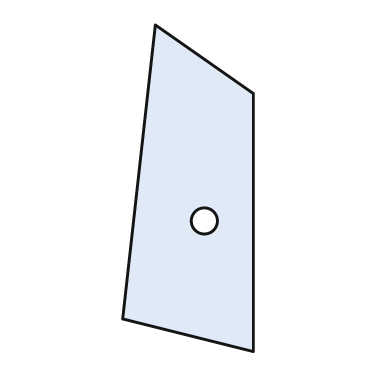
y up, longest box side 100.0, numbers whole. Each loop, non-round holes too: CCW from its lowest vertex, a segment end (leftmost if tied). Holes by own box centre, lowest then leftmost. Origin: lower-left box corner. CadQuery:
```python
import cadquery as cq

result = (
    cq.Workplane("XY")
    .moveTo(40.0, 0.0)
    .lineTo(40.0, 79.0)
    .lineTo(10.0, 100.0)
    .lineTo(0.0, 10.0)
    .close()
    .moveTo(25.0, 40.0)
    .circle(4.0)
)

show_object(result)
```